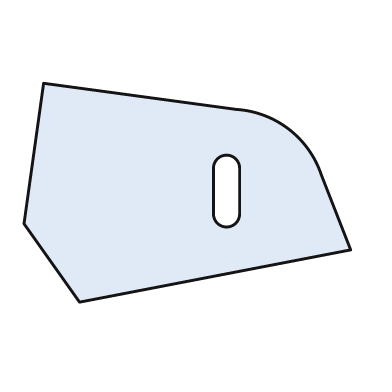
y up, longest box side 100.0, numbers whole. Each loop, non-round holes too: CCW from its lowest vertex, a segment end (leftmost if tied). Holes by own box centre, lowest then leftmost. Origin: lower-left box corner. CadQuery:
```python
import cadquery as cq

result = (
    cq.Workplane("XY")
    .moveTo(17.0, 0.0)
    .lineTo(100.0, 16.0)
    .lineTo(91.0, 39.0)
    .threePointArc((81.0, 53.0), (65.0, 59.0))
    .lineTo(6.0, 67.0)
    .lineTo(0.0, 24.0)
    .close()
    .moveTo(58.0, 27.0)
    .threePointArc((62.0, 23.0), (66.0, 27.0))
    .lineTo(66.0, 41.0)
    .threePointArc((62.0, 45.0), (58.0, 41.0))
    .close()
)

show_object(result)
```